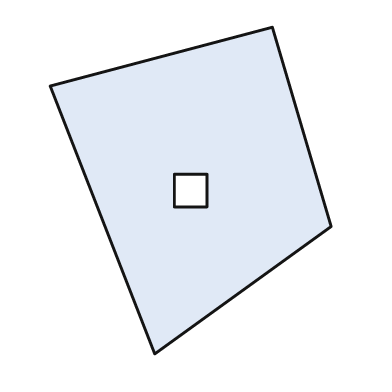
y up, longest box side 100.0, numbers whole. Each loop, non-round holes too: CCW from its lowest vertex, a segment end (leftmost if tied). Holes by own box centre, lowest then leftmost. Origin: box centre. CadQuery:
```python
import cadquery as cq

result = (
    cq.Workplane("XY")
    .moveTo(-11.0, -50.0)
    .lineTo(43.0, -11.0)
    .lineTo(25.0, 50.0)
    .lineTo(-43.0, 32.0)
    .close()
    .moveTo(-5.0, -5.0)
    .lineTo(5.0, -5.0)
    .lineTo(5.0, 5.0)
    .lineTo(-5.0, 5.0)
    .close()
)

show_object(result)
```